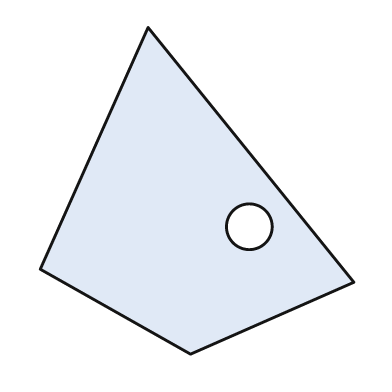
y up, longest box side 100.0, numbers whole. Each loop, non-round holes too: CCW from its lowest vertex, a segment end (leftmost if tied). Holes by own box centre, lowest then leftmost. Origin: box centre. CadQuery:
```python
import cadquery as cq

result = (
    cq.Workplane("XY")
    .moveTo(-2.0, -50.0)
    .lineTo(48.0, -28.0)
    .lineTo(-15.0, 50.0)
    .lineTo(-48.0, -24.0)
    .close()
    .moveTo(16.0, -11.0)
    .circle(7.0)
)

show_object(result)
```